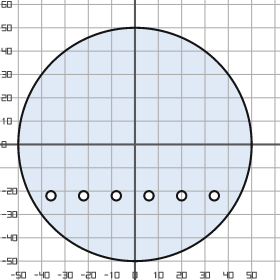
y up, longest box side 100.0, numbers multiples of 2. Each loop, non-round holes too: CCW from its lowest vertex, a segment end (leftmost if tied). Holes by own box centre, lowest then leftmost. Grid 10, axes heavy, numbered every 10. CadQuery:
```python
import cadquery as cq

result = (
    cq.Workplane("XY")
    .moveTo(0.0, 0.0)
    .circle(50.0)
    .moveTo(-36.0, -22.0)
    .circle(2.0)
    .moveTo(-22.0, -22.0)
    .circle(2.0)
    .moveTo(-8.0, -22.0)
    .circle(2.0)
    .moveTo(6.0, -22.0)
    .circle(2.0)
    .moveTo(20.0, -22.0)
    .circle(2.0)
    .moveTo(34.0, -22.0)
    .circle(2.0)
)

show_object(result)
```